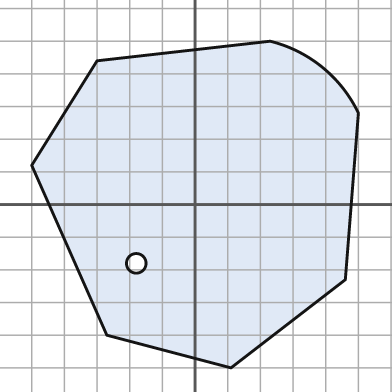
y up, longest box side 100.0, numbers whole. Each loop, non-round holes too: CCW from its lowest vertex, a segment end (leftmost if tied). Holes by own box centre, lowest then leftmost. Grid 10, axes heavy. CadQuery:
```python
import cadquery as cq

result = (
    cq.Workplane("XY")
    .moveTo(11.0, -50.0)
    .lineTo(46.0, -23.0)
    .lineTo(50.0, 28.0)
    .threePointArc((39.0, 42.0), (23.0, 50.0))
    .lineTo(-30.0, 44.0)
    .lineTo(-50.0, 12.0)
    .lineTo(-27.0, -40.0)
    .close()
    .moveTo(-18.0, -18.0)
    .circle(3.0)
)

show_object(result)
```